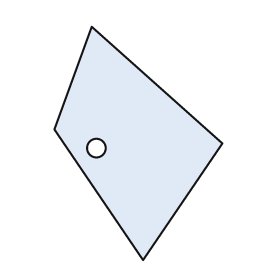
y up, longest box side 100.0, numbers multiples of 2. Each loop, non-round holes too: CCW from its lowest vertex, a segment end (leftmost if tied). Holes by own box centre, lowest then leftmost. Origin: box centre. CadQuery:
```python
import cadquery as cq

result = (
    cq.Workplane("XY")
    .moveTo(2.0, -50.0)
    .lineTo(36.0, 0.0)
    .lineTo(-20.0, 50.0)
    .lineTo(-36.0, 6.0)
    .close()
    .moveTo(-18.0, -2.0)
    .circle(4.0)
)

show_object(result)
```